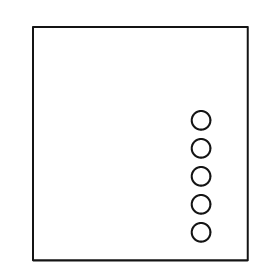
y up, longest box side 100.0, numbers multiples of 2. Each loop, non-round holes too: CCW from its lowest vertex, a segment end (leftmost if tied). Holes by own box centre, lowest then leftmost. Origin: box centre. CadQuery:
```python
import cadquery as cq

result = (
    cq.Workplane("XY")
    .moveTo(-46.0, -50.0)
    .lineTo(46.0, -50.0)
    .lineTo(46.0, 50.0)
    .lineTo(-46.0, 50.0)
    .close()
    .moveTo(26.0, -38.0)
    .circle(4.0)
    .moveTo(26.0, -26.0)
    .circle(4.0)
    .moveTo(26.0, -14.0)
    .circle(4.0)
    .moveTo(26.0, -2.0)
    .circle(4.0)
    .moveTo(26.0, 10.0)
    .circle(4.0)
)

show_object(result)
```